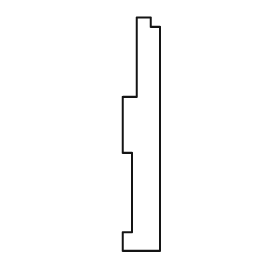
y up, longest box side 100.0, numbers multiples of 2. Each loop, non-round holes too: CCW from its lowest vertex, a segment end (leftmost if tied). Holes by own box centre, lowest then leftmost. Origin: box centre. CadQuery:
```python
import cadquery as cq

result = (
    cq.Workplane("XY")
    .moveTo(-8.0, -50.0)
    .lineTo(8.0, -50.0)
    .lineTo(8.0, 46.0)
    .lineTo(4.0, 46.0)
    .lineTo(4.0, 50.0)
    .lineTo(-2.0, 50.0)
    .lineTo(-2.0, 16.0)
    .lineTo(-8.0, 16.0)
    .lineTo(-8.0, -8.0)
    .lineTo(-4.0, -8.0)
    .lineTo(-4.0, -42.0)
    .lineTo(-8.0, -42.0)
    .close()
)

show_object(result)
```